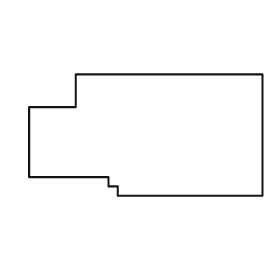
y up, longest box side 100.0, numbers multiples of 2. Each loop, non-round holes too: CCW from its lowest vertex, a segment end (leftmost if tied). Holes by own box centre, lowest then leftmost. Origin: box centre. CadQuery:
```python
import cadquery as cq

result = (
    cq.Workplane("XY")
    .moveTo(-12.0, -26.0)
    .lineTo(50.0, -26.0)
    .lineTo(50.0, 26.0)
    .lineTo(-30.0, 26.0)
    .lineTo(-30.0, 12.0)
    .lineTo(-50.0, 12.0)
    .lineTo(-50.0, -18.0)
    .lineTo(-16.0, -18.0)
    .lineTo(-16.0, -22.0)
    .lineTo(-12.0, -22.0)
    .close()
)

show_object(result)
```